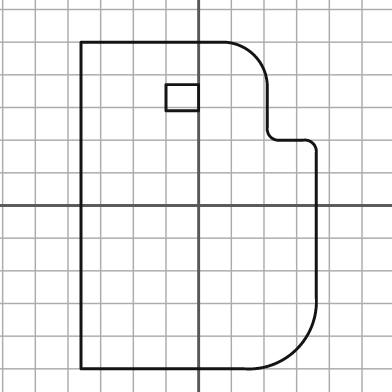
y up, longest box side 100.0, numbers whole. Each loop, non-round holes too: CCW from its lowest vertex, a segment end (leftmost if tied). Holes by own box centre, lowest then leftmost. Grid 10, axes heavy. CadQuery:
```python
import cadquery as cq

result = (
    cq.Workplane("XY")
    .moveTo(-36.0, -50.0)
    .lineTo(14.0, -50.0)
    .threePointArc((30.0, -44.0), (36.0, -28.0))
    .lineTo(36.0, 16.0)
    .threePointArc((35.0, 19.0), (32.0, 20.0))
    .lineTo(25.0, 20.0)
    .threePointArc((22.0, 21.0), (21.0, 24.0))
    .lineTo(21.0, 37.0)
    .threePointArc((17.0, 46.0), (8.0, 50.0))
    .lineTo(-36.0, 50.0)
    .close()
    .moveTo(-10.0, 29.0)
    .lineTo(0.0, 29.0)
    .lineTo(0.0, 37.0)
    .lineTo(-10.0, 37.0)
    .close()
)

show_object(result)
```